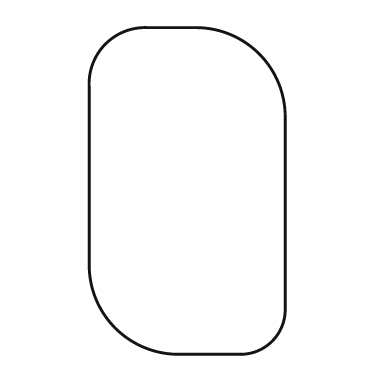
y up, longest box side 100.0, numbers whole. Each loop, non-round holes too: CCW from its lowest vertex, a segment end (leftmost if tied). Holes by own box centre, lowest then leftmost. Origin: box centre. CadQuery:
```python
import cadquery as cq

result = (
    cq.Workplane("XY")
    .moveTo(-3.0, -50.0)
    .lineTo(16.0, -50.0)
    .threePointArc((26.0, -46.0), (30.0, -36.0))
    .lineTo(30.0, 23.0)
    .threePointArc((22.0, 42.0), (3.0, 50.0))
    .lineTo(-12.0, 50.0)
    .threePointArc((-25.0, 45.0), (-30.0, 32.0))
    .lineTo(-30.0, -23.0)
    .threePointArc((-22.0, -42.0), (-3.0, -50.0))
    .close()
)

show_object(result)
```